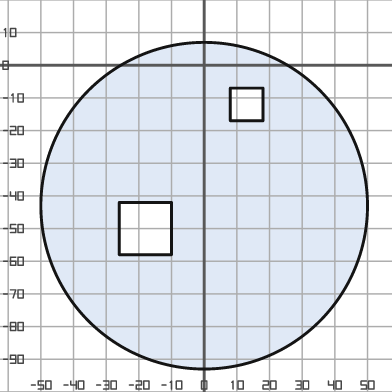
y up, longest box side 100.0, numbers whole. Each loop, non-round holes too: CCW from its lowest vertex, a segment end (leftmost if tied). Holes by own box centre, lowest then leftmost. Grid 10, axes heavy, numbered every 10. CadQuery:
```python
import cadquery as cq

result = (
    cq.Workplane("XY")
    .moveTo(0.0, -43.0)
    .circle(50.0)
    .moveTo(-26.0, -58.0)
    .lineTo(-10.0, -58.0)
    .lineTo(-10.0, -42.0)
    .lineTo(-26.0, -42.0)
    .close()
    .moveTo(8.0, -17.0)
    .lineTo(18.0, -17.0)
    .lineTo(18.0, -7.0)
    .lineTo(8.0, -7.0)
    .close()
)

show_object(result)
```